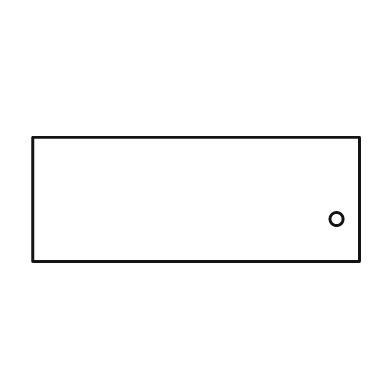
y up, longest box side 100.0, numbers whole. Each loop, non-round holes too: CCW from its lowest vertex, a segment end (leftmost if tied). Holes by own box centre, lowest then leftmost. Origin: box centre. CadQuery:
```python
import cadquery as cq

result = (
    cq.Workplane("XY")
    .moveTo(-50.0, -19.0)
    .lineTo(50.0, -19.0)
    .lineTo(50.0, 19.0)
    .lineTo(-50.0, 19.0)
    .close()
    .moveTo(43.0, -6.0)
    .circle(2.0)
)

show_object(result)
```